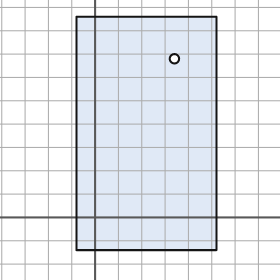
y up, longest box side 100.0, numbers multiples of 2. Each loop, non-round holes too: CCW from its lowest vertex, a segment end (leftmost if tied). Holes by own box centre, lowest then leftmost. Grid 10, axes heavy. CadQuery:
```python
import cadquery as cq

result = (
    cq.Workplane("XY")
    .moveTo(-8.0, -14.0)
    .lineTo(52.0, -14.0)
    .lineTo(52.0, 86.0)
    .lineTo(-8.0, 86.0)
    .close()
    .moveTo(34.0, 68.0)
    .circle(2.0)
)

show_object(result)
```